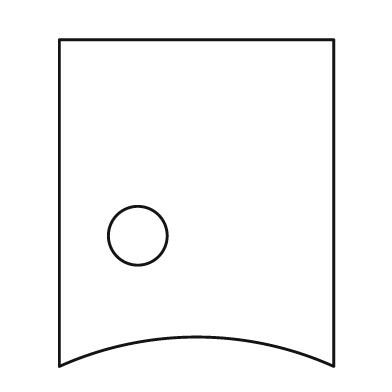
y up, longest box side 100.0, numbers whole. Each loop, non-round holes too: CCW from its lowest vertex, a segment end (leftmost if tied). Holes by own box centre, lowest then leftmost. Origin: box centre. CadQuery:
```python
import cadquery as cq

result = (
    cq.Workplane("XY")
    .moveTo(-42.0, -50.0)
    .threePointArc((0.0, -41.0), (42.0, -50.0))
    .lineTo(42.0, 50.0)
    .lineTo(-42.0, 50.0)
    .close()
    .moveTo(-18.0, -10.0)
    .circle(9.0)
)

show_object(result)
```